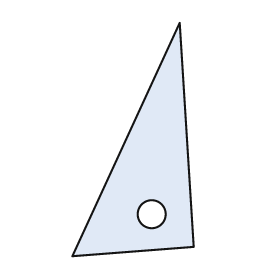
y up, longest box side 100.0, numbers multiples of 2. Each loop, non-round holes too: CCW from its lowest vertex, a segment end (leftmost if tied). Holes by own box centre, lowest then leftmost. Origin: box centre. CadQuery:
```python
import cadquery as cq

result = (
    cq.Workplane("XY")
    .moveTo(-26.0, -50.0)
    .lineTo(26.0, -46.0)
    .lineTo(20.0, 50.0)
    .close()
    .moveTo(8.0, -32.0)
    .circle(6.0)
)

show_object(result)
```